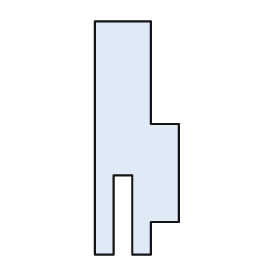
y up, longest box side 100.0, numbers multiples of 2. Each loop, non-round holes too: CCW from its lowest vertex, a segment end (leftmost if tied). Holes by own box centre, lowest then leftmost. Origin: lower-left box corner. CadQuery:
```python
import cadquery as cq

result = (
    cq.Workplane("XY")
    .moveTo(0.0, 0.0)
    .lineTo(8.0, 0.0)
    .lineTo(8.0, 34.0)
    .lineTo(16.0, 34.0)
    .lineTo(16.0, 0.0)
    .lineTo(24.0, 0.0)
    .lineTo(24.0, 14.0)
    .lineTo(36.0, 14.0)
    .lineTo(36.0, 56.0)
    .lineTo(24.0, 56.0)
    .lineTo(24.0, 100.0)
    .lineTo(0.0, 100.0)
    .close()
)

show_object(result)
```